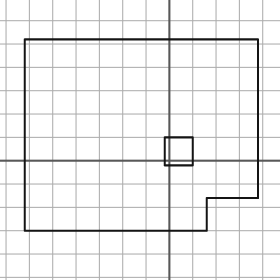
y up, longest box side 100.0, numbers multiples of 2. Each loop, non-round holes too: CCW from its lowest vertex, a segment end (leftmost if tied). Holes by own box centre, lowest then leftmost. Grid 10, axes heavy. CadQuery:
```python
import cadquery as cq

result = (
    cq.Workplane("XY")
    .moveTo(-62.0, -30.0)
    .lineTo(16.0, -30.0)
    .lineTo(16.0, -16.0)
    .lineTo(38.0, -16.0)
    .lineTo(38.0, 52.0)
    .lineTo(-62.0, 52.0)
    .close()
    .moveTo(-2.0, -2.0)
    .lineTo(10.0, -2.0)
    .lineTo(10.0, 10.0)
    .lineTo(-2.0, 10.0)
    .close()
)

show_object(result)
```